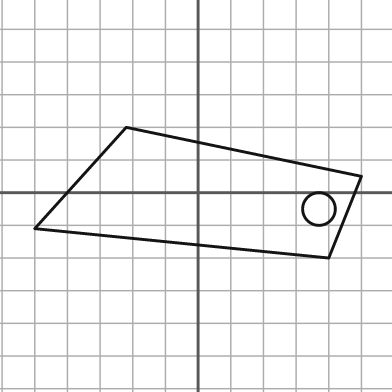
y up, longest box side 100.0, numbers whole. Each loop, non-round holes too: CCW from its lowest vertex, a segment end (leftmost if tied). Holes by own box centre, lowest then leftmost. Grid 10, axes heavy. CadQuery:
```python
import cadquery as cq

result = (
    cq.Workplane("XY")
    .moveTo(40.0, -20.0)
    .lineTo(50.0, 5.0)
    .lineTo(-22.0, 20.0)
    .lineTo(-50.0, -11.0)
    .close()
    .moveTo(37.0, -5.0)
    .circle(5.0)
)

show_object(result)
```